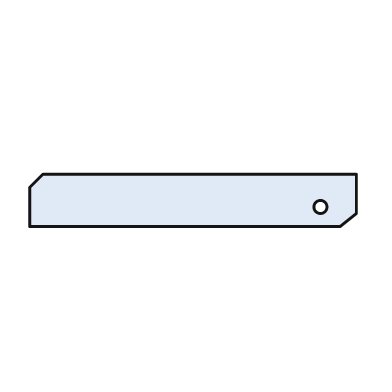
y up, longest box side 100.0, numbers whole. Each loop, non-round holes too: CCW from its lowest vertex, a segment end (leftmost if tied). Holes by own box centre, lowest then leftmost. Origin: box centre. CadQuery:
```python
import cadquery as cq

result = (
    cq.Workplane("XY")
    .moveTo(-50.0, -8.0)
    .lineTo(45.0, -8.0)
    .lineTo(50.0, -4.0)
    .lineTo(50.0, 8.0)
    .lineTo(-46.0, 8.0)
    .lineTo(-50.0, 4.0)
    .close()
    .moveTo(39.0, -2.0)
    .circle(2.0)
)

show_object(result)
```